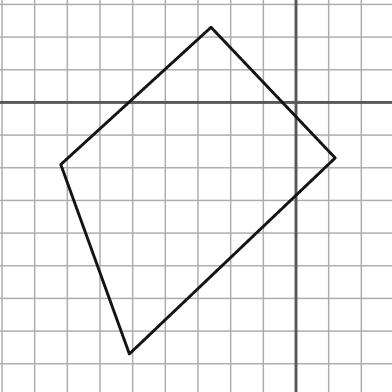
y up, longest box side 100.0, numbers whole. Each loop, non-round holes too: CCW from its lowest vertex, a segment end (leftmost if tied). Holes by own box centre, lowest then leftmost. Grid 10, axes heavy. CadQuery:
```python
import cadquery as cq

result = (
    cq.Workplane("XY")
    .moveTo(-51.0, -77.0)
    .lineTo(12.0, -17.0)
    .lineTo(-26.0, 23.0)
    .lineTo(-72.0, -19.0)
    .close()
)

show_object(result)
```